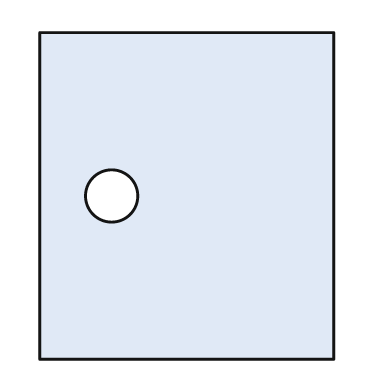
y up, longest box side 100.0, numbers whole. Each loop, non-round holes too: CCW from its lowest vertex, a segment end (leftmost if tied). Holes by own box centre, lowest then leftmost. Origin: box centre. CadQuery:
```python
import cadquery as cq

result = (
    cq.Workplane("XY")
    .moveTo(-45.0, -50.0)
    .lineTo(45.0, -50.0)
    .lineTo(45.0, 50.0)
    .lineTo(-45.0, 50.0)
    .close()
    .moveTo(-23.0, 0.0)
    .circle(8.0)
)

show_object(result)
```